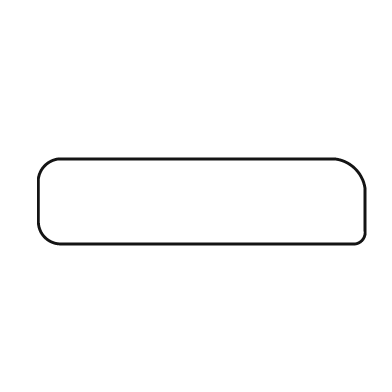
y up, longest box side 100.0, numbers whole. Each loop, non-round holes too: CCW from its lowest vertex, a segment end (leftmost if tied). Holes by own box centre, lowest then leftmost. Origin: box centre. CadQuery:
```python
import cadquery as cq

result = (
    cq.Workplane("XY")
    .moveTo(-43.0, -13.0)
    .lineTo(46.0, -13.0)
    .threePointArc((49.0, -12.0), (50.0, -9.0))
    .lineTo(50.0, 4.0)
    .threePointArc((47.0, 10.0), (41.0, 13.0))
    .lineTo(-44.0, 13.0)
    .threePointArc((-48.0, 11.0), (-50.0, 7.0))
    .lineTo(-50.0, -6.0)
    .threePointArc((-48.0, -11.0), (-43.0, -13.0))
    .close()
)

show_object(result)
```